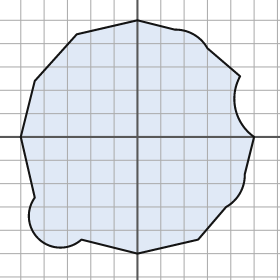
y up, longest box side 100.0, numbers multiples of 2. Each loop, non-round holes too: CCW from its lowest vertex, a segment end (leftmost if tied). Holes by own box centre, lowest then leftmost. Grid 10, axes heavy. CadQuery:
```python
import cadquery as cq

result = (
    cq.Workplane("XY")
    .moveTo(0.0, -50.0)
    .lineTo(26.0, -44.0)
    .lineTo(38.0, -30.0)
    .threePointArc((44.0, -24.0), (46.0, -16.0))
    .lineTo(50.0, 0.0)
    .threePointArc((42.0, 12.0), (44.0, 26.0))
    .lineTo(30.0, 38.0)
    .threePointArc((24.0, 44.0), (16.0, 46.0))
    .lineTo(0.0, 50.0)
    .lineTo(-26.0, 44.0)
    .lineTo(-44.0, 24.0)
    .lineTo(-50.0, 0.0)
    .lineTo(-44.0, -26.0)
    .threePointArc((-42.0, -44.0), (-24.0, -44.0))
    .close()
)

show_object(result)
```